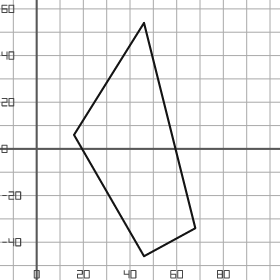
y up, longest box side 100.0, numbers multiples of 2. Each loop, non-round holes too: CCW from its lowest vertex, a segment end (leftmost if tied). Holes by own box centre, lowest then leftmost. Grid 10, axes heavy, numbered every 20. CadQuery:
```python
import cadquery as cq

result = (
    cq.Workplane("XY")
    .moveTo(46.0, -46.0)
    .lineTo(68.0, -34.0)
    .lineTo(46.0, 54.0)
    .lineTo(16.0, 6.0)
    .close()
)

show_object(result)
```